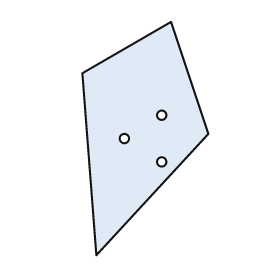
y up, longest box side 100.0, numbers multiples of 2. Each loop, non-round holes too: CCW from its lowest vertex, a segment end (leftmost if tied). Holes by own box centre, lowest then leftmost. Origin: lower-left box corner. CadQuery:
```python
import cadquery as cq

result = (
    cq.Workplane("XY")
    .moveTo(6.0, 0.0)
    .lineTo(54.0, 52.0)
    .lineTo(38.0, 100.0)
    .lineTo(0.0, 78.0)
    .close()
    .moveTo(34.0, 40.0)
    .circle(2.0)
    .moveTo(18.0, 50.0)
    .circle(2.0)
    .moveTo(34.0, 60.0)
    .circle(2.0)
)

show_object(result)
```